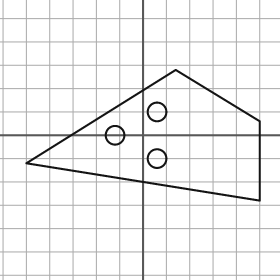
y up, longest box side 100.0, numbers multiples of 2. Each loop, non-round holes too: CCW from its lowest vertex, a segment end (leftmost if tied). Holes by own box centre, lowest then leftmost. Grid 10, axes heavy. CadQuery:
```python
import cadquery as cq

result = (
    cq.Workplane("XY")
    .moveTo(50.0, -28.0)
    .lineTo(50.0, 6.0)
    .lineTo(14.0, 28.0)
    .lineTo(-50.0, -12.0)
    .close()
    .moveTo(6.0, -10.0)
    .circle(4.0)
    .moveTo(-12.0, 0.0)
    .circle(4.0)
    .moveTo(6.0, 10.0)
    .circle(4.0)
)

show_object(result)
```